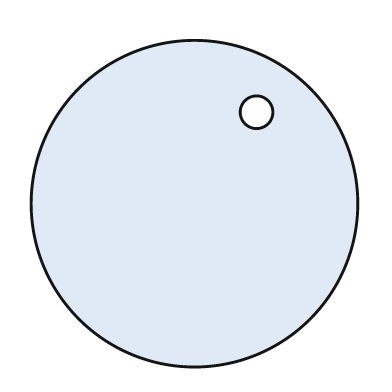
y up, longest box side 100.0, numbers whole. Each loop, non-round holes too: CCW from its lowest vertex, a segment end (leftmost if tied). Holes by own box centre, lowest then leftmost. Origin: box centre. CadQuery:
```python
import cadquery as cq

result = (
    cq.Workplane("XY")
    .moveTo(0.0, 0.0)
    .circle(50.0)
    .moveTo(19.0, 28.0)
    .circle(5.0)
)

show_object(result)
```